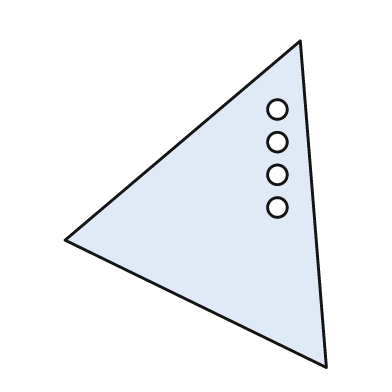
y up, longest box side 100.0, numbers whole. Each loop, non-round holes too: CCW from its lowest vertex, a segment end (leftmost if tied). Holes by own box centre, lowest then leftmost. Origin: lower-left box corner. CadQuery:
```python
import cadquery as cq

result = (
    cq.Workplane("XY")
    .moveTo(80.0, 0.0)
    .lineTo(72.0, 100.0)
    .lineTo(0.0, 39.0)
    .close()
    .moveTo(65.0, 49.0)
    .circle(3.0)
    .moveTo(65.0, 59.0)
    .circle(3.0)
    .moveTo(65.0, 69.0)
    .circle(3.0)
    .moveTo(65.0, 79.0)
    .circle(3.0)
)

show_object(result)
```